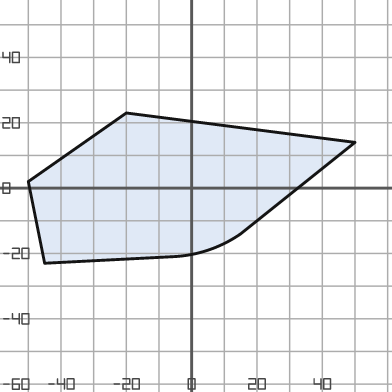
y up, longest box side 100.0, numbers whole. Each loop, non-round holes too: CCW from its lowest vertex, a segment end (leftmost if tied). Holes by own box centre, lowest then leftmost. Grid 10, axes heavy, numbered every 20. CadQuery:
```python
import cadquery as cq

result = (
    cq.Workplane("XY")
    .moveTo(-45.0, -23.0)
    .lineTo(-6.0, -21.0)
    .threePointArc((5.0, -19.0), (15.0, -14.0))
    .lineTo(50.0, 14.0)
    .lineTo(-20.0, 23.0)
    .lineTo(-50.0, 2.0)
    .close()
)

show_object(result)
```